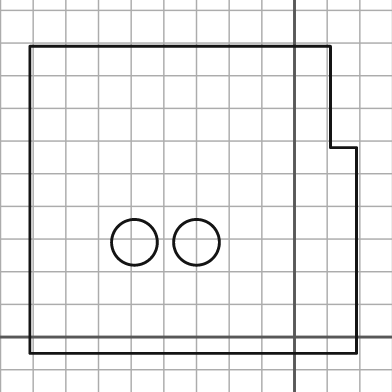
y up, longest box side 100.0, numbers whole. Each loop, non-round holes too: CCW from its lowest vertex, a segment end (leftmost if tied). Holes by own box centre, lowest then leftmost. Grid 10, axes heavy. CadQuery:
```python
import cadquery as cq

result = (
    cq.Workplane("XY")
    .moveTo(-81.0, -5.0)
    .lineTo(19.0, -5.0)
    .lineTo(19.0, 58.0)
    .lineTo(11.0, 58.0)
    .lineTo(11.0, 89.0)
    .lineTo(-81.0, 89.0)
    .close()
    .moveTo(-49.0, 29.0)
    .circle(7.0)
    .moveTo(-30.0, 29.0)
    .circle(7.0)
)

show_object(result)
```